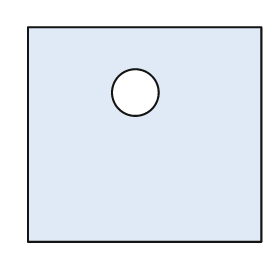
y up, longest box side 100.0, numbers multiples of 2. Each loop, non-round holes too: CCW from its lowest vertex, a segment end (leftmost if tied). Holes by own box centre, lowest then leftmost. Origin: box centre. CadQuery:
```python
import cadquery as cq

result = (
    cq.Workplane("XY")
    .moveTo(-50.0, -46.0)
    .lineTo(50.0, -46.0)
    .lineTo(50.0, 46.0)
    .lineTo(-50.0, 46.0)
    .close()
    .moveTo(-4.0, 18.0)
    .circle(10.0)
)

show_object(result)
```